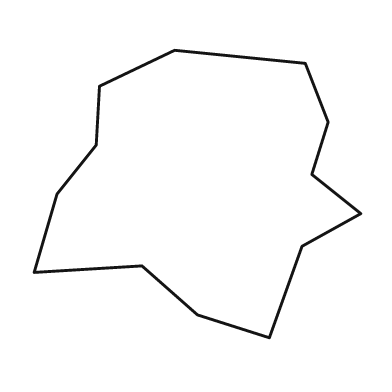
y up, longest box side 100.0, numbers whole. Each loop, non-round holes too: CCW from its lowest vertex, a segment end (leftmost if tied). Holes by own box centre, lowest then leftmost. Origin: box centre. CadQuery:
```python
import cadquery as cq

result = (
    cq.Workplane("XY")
    .moveTo(22.0, -44.0)
    .lineTo(32.0, -16.0)
    .lineTo(50.0, -6.0)
    .lineTo(35.0, 6.0)
    .lineTo(40.0, 22.0)
    .lineTo(33.0, 40.0)
    .lineTo(-7.0, 44.0)
    .lineTo(-30.0, 33.0)
    .lineTo(-31.0, 15.0)
    .lineTo(-43.0, 0.0)
    .lineTo(-50.0, -24.0)
    .lineTo(-17.0, -22.0)
    .lineTo(0.0, -37.0)
    .close()
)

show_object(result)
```